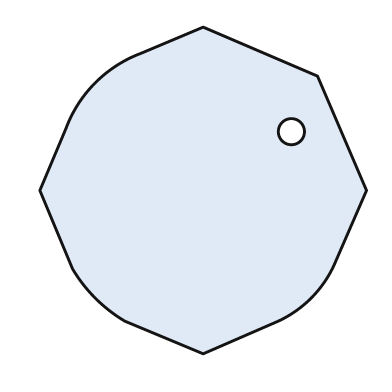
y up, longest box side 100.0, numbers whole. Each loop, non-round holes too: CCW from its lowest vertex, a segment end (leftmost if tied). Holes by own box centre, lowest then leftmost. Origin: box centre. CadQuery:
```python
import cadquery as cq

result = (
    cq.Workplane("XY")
    .moveTo(0.0, -50.0)
    .lineTo(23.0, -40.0)
    .threePointArc((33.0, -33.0), (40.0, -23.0))
    .lineTo(50.0, 0.0)
    .lineTo(35.0, 35.0)
    .lineTo(0.0, 50.0)
    .lineTo(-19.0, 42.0)
    .threePointArc((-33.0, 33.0), (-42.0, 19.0))
    .lineTo(-50.0, 0.0)
    .lineTo(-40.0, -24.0)
    .threePointArc((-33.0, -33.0), (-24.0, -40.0))
    .close()
    .moveTo(27.0, 18.0)
    .circle(4.0)
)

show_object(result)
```